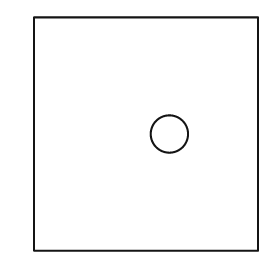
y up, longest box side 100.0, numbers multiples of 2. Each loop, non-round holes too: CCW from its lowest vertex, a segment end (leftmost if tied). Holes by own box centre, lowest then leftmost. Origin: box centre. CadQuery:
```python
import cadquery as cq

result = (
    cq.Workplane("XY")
    .moveTo(-48.0, -50.0)
    .lineTo(48.0, -50.0)
    .lineTo(48.0, 50.0)
    .lineTo(-48.0, 50.0)
    .close()
    .moveTo(10.0, 0.0)
    .circle(8.0)
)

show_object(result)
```